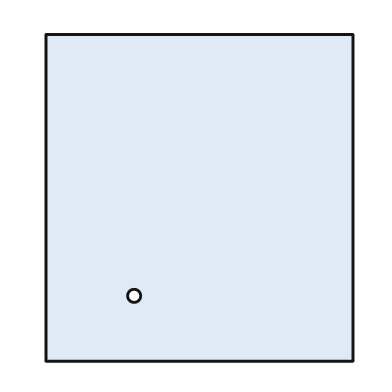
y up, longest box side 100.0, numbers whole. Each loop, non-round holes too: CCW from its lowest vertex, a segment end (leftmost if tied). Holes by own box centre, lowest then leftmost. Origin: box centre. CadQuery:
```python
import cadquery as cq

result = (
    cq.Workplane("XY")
    .moveTo(-47.0, -50.0)
    .lineTo(47.0, -50.0)
    .lineTo(47.0, 50.0)
    .lineTo(-47.0, 50.0)
    .close()
    .moveTo(-20.0, -30.0)
    .circle(2.0)
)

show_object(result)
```